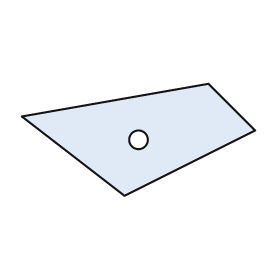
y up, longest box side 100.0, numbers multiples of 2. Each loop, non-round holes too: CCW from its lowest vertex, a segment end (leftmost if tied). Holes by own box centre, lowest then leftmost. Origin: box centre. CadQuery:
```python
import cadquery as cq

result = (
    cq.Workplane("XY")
    .moveTo(-6.0, -24.0)
    .lineTo(50.0, 4.0)
    .lineTo(30.0, 24.0)
    .lineTo(-50.0, 10.0)
    .close()
    .moveTo(0.0, 0.0)
    .circle(4.0)
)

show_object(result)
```